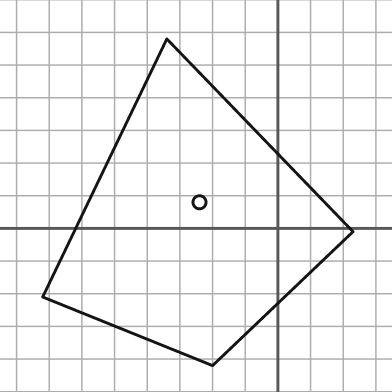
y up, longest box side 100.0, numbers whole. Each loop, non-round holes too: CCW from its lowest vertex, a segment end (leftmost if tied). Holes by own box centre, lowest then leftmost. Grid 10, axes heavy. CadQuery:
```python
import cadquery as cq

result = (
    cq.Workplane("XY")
    .moveTo(-20.0, -42.0)
    .lineTo(23.0, -1.0)
    .lineTo(-34.0, 58.0)
    .lineTo(-72.0, -21.0)
    .close()
    .moveTo(-24.0, 8.0)
    .circle(2.0)
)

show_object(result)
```